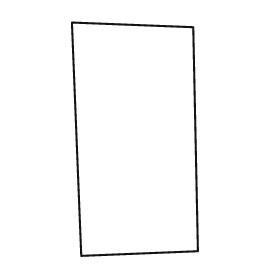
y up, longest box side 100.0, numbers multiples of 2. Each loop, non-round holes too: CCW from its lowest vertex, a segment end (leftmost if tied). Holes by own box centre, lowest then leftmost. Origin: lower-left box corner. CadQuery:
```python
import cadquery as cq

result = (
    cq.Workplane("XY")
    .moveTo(4.0, 0.0)
    .lineTo(54.0, 2.0)
    .lineTo(52.0, 98.0)
    .lineTo(0.0, 100.0)
    .close()
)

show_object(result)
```